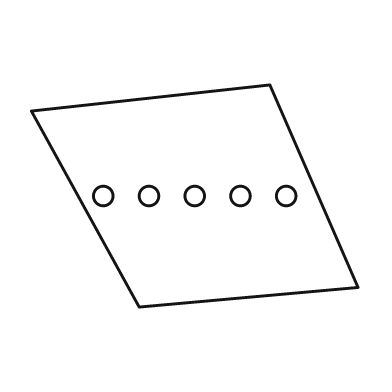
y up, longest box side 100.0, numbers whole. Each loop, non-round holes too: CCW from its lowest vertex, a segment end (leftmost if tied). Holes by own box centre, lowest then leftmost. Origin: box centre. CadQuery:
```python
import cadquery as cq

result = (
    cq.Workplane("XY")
    .moveTo(-17.0, -34.0)
    .lineTo(50.0, -28.0)
    .lineTo(23.0, 34.0)
    .lineTo(-50.0, 26.0)
    .close()
    .moveTo(-28.0, 0.0)
    .circle(3.0)
    .moveTo(-14.0, 0.0)
    .circle(3.0)
    .moveTo(0.0, 0.0)
    .circle(3.0)
    .moveTo(14.0, 0.0)
    .circle(3.0)
    .moveTo(28.0, 0.0)
    .circle(3.0)
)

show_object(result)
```